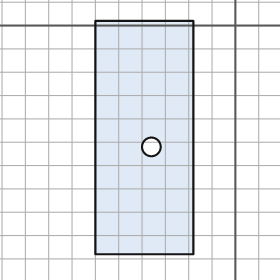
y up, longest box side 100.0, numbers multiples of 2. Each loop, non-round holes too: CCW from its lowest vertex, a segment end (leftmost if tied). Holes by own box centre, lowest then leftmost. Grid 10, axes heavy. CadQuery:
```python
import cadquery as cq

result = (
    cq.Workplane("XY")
    .moveTo(-60.0, -98.0)
    .lineTo(-18.0, -98.0)
    .lineTo(-18.0, 2.0)
    .lineTo(-60.0, 2.0)
    .close()
    .moveTo(-36.0, -52.0)
    .circle(4.0)
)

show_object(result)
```